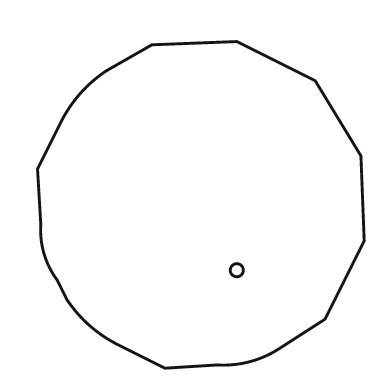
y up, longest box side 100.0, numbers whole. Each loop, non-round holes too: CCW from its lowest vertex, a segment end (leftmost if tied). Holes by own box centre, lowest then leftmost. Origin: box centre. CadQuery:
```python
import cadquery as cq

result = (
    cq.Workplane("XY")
    .moveTo(-11.0, -50.0)
    .lineTo(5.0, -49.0)
    .threePointArc((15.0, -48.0), (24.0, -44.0))
    .lineTo(38.0, -35.0)
    .lineTo(50.0, -11.0)
    .lineTo(49.0, 15.0)
    .lineTo(35.0, 38.0)
    .lineTo(11.0, 50.0)
    .lineTo(-15.0, 49.0)
    .lineTo(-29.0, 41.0)
    .threePointArc((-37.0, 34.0), (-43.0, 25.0))
    .lineTo(-50.0, 11.0)
    .lineTo(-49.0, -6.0)
    .threePointArc((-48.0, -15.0), (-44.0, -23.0))
    .lineTo(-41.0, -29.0)
    .threePointArc((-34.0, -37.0), (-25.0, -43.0))
    .close()
    .moveTo(11.0, -20.0)
    .circle(2.0)
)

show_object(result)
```